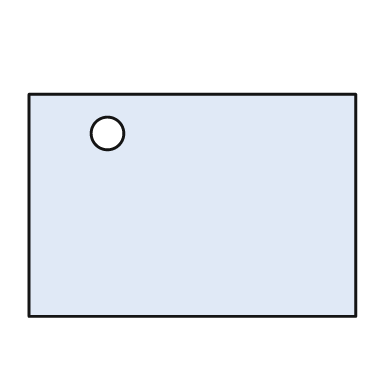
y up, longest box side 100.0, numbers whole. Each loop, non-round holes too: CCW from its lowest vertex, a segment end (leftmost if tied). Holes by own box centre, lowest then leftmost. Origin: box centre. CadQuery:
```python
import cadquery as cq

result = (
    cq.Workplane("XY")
    .moveTo(-50.0, -34.0)
    .lineTo(50.0, -34.0)
    .lineTo(50.0, 34.0)
    .lineTo(-50.0, 34.0)
    .close()
    .moveTo(-26.0, 22.0)
    .circle(5.0)
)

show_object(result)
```